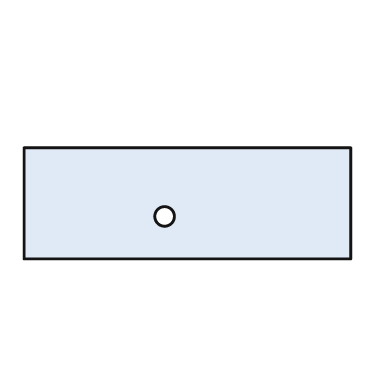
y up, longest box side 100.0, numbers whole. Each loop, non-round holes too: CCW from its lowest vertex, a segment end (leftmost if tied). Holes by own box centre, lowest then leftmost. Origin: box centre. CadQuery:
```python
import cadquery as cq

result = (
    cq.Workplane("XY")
    .moveTo(-50.0, -17.0)
    .lineTo(50.0, -17.0)
    .lineTo(50.0, 17.0)
    .lineTo(-50.0, 17.0)
    .close()
    .moveTo(-7.0, -4.0)
    .circle(3.0)
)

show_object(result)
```